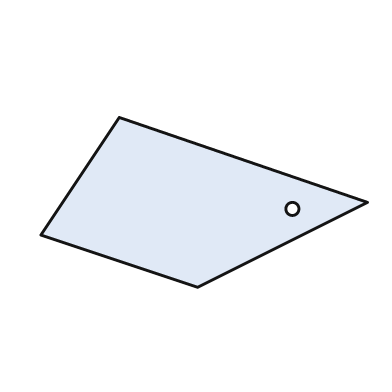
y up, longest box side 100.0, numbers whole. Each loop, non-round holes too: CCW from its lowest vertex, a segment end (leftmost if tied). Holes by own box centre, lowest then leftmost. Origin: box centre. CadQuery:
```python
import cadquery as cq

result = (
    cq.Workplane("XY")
    .moveTo(-2.0, -26.0)
    .lineTo(50.0, 0.0)
    .lineTo(-26.0, 26.0)
    .lineTo(-50.0, -10.0)
    .close()
    .moveTo(27.0, -2.0)
    .circle(2.0)
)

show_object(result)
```